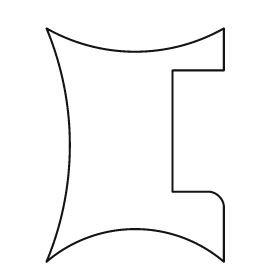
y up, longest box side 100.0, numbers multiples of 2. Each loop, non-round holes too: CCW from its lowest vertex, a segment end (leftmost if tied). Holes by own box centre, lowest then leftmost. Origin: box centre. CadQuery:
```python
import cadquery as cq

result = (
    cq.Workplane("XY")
    .moveTo(-38.0, -50.0)
    .threePointArc((0.0, -36.0), (38.0, -50.0))
    .lineTo(38.0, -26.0)
    .threePointArc((36.0, -22.0), (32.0, -20.0))
    .lineTo(16.0, -20.0)
    .lineTo(16.0, 32.0)
    .lineTo(38.0, 32.0)
    .lineTo(38.0, 50.0)
    .threePointArc((0.0, 40.0), (-38.0, 50.0))
    .threePointArc((-28.0, 0.0), (-38.0, -50.0))
    .close()
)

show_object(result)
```